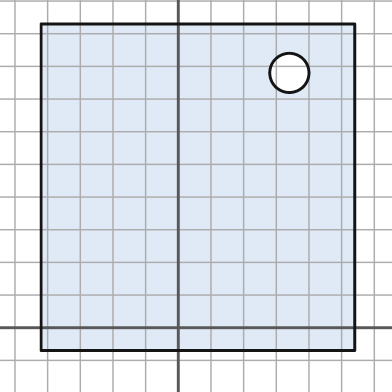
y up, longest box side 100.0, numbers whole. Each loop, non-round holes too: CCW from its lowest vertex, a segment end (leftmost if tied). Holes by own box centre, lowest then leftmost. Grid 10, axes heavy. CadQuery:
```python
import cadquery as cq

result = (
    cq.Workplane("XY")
    .moveTo(-42.0, -7.0)
    .lineTo(54.0, -7.0)
    .lineTo(54.0, 93.0)
    .lineTo(-42.0, 93.0)
    .close()
    .moveTo(34.0, 78.0)
    .circle(6.0)
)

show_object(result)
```